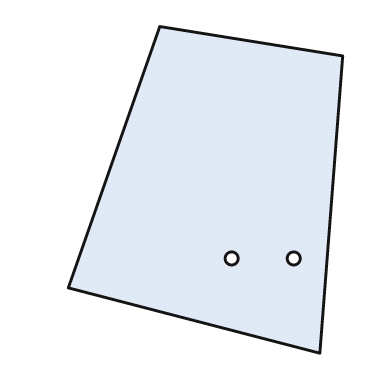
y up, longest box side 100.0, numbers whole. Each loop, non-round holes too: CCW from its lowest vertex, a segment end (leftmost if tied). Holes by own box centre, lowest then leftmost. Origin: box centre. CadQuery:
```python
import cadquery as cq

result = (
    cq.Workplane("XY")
    .moveTo(35.0, -50.0)
    .lineTo(42.0, 41.0)
    .lineTo(-14.0, 50.0)
    .lineTo(-42.0, -30.0)
    .close()
    .moveTo(8.0, -21.0)
    .circle(2.0)
    .moveTo(27.0, -21.0)
    .circle(2.0)
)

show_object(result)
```